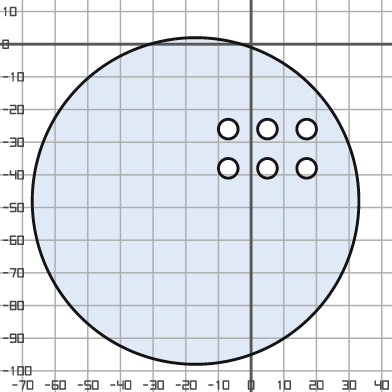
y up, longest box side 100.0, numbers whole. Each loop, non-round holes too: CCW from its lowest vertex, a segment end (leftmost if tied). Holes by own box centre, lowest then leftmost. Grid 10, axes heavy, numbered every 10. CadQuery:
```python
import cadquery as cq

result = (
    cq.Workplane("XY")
    .moveTo(-17.0, -48.0)
    .circle(50.0)
    .moveTo(-7.0, -38.0)
    .circle(3.0)
    .moveTo(5.0, -38.0)
    .circle(3.0)
    .moveTo(17.0, -38.0)
    .circle(3.0)
    .moveTo(-7.0, -26.0)
    .circle(3.0)
    .moveTo(5.0, -26.0)
    .circle(3.0)
    .moveTo(17.0, -26.0)
    .circle(3.0)
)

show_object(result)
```